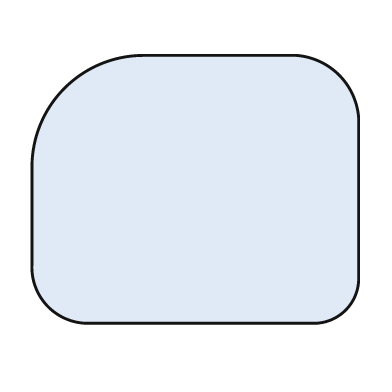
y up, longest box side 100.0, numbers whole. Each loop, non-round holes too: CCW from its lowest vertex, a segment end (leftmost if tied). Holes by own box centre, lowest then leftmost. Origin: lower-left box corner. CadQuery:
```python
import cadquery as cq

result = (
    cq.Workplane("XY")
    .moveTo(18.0, 0.0)
    .lineTo(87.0, 0.0)
    .threePointArc((96.0, 4.0), (100.0, 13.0))
    .lineTo(100.0, 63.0)
    .threePointArc((94.0, 76.0), (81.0, 82.0))
    .lineTo(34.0, 82.0)
    .threePointArc((10.0, 72.0), (0.0, 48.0))
    .lineTo(0.0, 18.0)
    .threePointArc((5.0, 5.0), (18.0, 0.0))
    .close()
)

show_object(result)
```